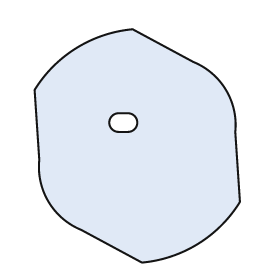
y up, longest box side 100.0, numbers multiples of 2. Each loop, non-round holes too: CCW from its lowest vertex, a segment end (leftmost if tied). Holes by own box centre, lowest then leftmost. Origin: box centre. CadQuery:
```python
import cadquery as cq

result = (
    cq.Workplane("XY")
    .moveTo(2.0, -50.0)
    .threePointArc((26.0, -42.0), (44.0, -24.0))
    .lineTo(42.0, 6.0)
    .threePointArc((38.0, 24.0), (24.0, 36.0))
    .lineTo(-2.0, 50.0)
    .threePointArc((-26.0, 42.0), (-44.0, 24.0))
    .lineTo(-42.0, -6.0)
    .threePointArc((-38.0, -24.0), (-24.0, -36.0))
    .close()
    .moveTo(-8.0, 6.0)
    .lineTo(-4.0, 6.0)
    .threePointArc((0.0, 10.0), (-4.0, 14.0))
    .lineTo(-8.0, 14.0)
    .threePointArc((-12.0, 10.0), (-8.0, 6.0))
    .close()
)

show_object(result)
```